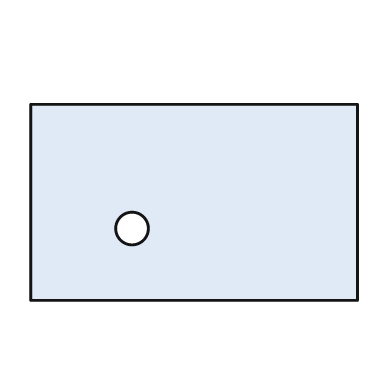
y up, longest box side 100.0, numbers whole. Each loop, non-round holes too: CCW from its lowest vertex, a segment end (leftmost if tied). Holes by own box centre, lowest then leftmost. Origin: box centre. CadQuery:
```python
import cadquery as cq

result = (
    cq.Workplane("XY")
    .moveTo(-50.0, -30.0)
    .lineTo(50.0, -30.0)
    .lineTo(50.0, 30.0)
    .lineTo(-50.0, 30.0)
    .close()
    .moveTo(-19.0, -8.0)
    .circle(5.0)
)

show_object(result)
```